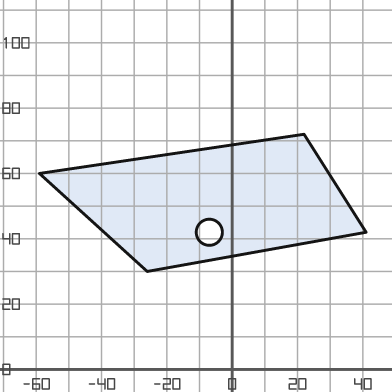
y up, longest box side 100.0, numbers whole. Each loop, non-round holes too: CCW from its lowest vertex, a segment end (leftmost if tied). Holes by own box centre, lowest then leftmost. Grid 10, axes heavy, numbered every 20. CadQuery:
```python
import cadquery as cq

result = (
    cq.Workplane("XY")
    .moveTo(-26.0, 30.0)
    .lineTo(41.0, 42.0)
    .lineTo(22.0, 72.0)
    .lineTo(-59.0, 60.0)
    .close()
    .moveTo(-7.0, 42.0)
    .circle(4.0)
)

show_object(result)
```